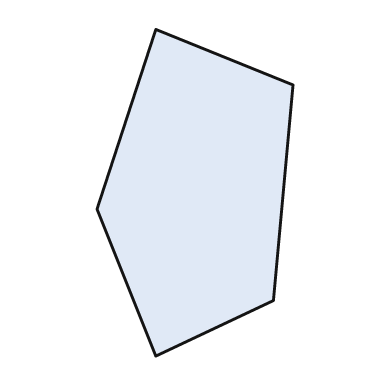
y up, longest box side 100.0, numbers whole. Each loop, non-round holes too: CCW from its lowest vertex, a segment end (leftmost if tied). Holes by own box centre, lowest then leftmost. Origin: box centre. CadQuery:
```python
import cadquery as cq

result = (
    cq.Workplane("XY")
    .moveTo(-12.0, -50.0)
    .lineTo(24.0, -33.0)
    .lineTo(30.0, 33.0)
    .lineTo(-12.0, 50.0)
    .lineTo(-30.0, -5.0)
    .close()
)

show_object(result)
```